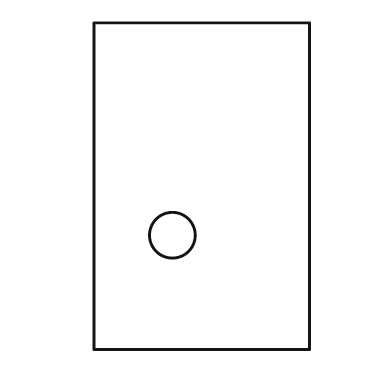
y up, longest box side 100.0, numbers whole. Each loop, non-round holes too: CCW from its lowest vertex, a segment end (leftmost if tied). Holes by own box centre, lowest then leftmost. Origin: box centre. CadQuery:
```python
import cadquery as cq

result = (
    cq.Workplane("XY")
    .moveTo(-33.0, -50.0)
    .lineTo(33.0, -50.0)
    .lineTo(33.0, 50.0)
    .lineTo(-33.0, 50.0)
    .close()
    .moveTo(-9.0, -15.0)
    .circle(7.0)
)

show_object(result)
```